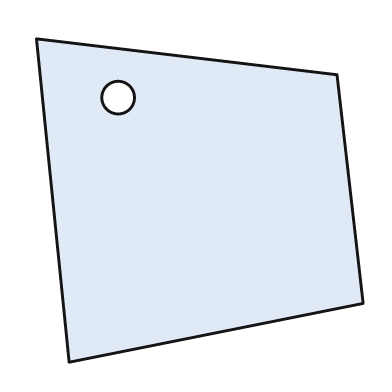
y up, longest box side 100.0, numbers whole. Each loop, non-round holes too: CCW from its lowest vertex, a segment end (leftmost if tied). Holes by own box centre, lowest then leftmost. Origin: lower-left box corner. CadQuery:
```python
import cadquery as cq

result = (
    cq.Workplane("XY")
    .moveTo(10.0, 0.0)
    .lineTo(100.0, 18.0)
    .lineTo(92.0, 88.0)
    .lineTo(0.0, 99.0)
    .close()
    .moveTo(25.0, 81.0)
    .circle(5.0)
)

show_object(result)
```